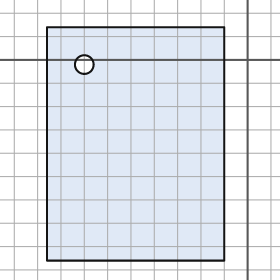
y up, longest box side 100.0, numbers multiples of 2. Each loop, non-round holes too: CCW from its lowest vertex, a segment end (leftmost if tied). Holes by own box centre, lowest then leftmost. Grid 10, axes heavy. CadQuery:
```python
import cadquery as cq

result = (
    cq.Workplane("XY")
    .moveTo(-86.0, -86.0)
    .lineTo(-10.0, -86.0)
    .lineTo(-10.0, 14.0)
    .lineTo(-86.0, 14.0)
    .close()
    .moveTo(-70.0, -2.0)
    .circle(4.0)
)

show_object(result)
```